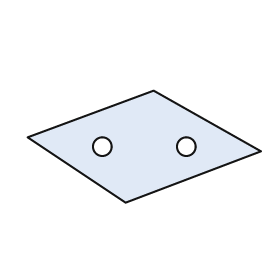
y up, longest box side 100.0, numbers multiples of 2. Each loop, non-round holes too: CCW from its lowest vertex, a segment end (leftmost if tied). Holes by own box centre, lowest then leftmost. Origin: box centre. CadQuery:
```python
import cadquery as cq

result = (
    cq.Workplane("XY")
    .moveTo(-8.0, -24.0)
    .lineTo(50.0, -2.0)
    .lineTo(4.0, 24.0)
    .lineTo(-50.0, 4.0)
    .close()
    .moveTo(-18.0, 0.0)
    .circle(4.0)
    .moveTo(18.0, 0.0)
    .circle(4.0)
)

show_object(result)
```